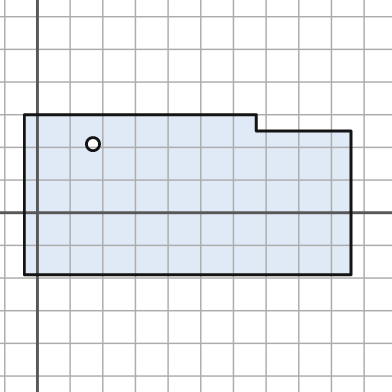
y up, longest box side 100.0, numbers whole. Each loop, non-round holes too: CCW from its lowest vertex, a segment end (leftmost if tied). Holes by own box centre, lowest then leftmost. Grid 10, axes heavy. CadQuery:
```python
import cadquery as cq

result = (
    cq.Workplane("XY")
    .moveTo(-4.0, -19.0)
    .lineTo(96.0, -19.0)
    .lineTo(96.0, 25.0)
    .lineTo(67.0, 25.0)
    .lineTo(67.0, 30.0)
    .lineTo(-4.0, 30.0)
    .close()
    .moveTo(17.0, 21.0)
    .circle(2.0)
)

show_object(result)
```